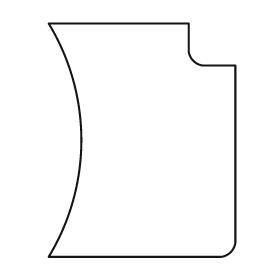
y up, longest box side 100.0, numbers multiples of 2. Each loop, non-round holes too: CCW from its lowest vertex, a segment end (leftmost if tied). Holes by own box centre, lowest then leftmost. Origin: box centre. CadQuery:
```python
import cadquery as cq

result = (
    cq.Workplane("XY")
    .moveTo(-40.0, -50.0)
    .lineTo(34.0, -50.0)
    .threePointArc((38.0, -48.0), (40.0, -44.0))
    .lineTo(40.0, 32.0)
    .lineTo(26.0, 32.0)
    .threePointArc((22.0, 34.0), (20.0, 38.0))
    .lineTo(20.0, 50.0)
    .lineTo(-40.0, 50.0)
    .threePointArc((-26.0, 0.0), (-40.0, -50.0))
    .close()
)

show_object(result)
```